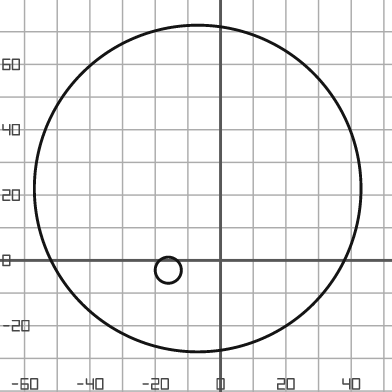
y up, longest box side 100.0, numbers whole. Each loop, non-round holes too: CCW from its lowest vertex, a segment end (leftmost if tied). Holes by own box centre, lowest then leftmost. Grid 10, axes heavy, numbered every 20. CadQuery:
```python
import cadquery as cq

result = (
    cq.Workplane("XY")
    .moveTo(-7.0, 22.0)
    .circle(50.0)
    .moveTo(-16.0, -3.0)
    .circle(4.0)
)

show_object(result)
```